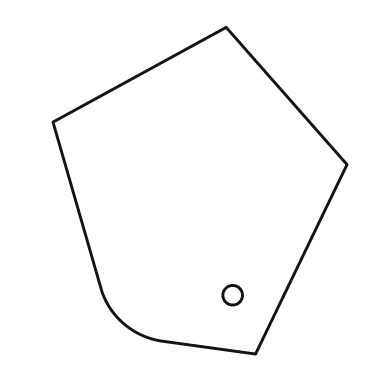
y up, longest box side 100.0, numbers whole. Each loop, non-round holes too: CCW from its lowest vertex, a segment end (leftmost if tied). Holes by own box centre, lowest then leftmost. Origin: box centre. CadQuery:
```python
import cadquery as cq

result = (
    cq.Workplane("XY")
    .moveTo(17.0, -50.0)
    .lineTo(45.0, 8.0)
    .lineTo(8.0, 50.0)
    .lineTo(-45.0, 21.0)
    .lineTo(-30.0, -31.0)
    .threePointArc((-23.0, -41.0), (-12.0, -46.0))
    .close()
    .moveTo(10.0, -32.0)
    .circle(3.0)
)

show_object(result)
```